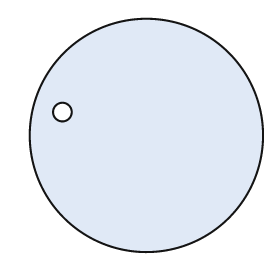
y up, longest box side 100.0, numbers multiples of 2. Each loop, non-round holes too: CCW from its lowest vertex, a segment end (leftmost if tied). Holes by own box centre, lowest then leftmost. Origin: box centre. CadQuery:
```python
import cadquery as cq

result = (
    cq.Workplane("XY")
    .moveTo(0.0, 0.0)
    .circle(50.0)
    .moveTo(-36.0, 10.0)
    .circle(4.0)
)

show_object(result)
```